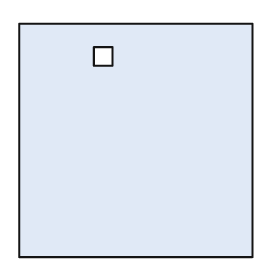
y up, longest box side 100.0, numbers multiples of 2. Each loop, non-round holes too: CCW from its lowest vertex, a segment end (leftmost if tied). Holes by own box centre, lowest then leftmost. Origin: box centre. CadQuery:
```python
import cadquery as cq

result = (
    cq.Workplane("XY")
    .moveTo(-50.0, -50.0)
    .lineTo(50.0, -50.0)
    .lineTo(50.0, 50.0)
    .lineTo(-50.0, 50.0)
    .close()
    .moveTo(-18.0, 32.0)
    .lineTo(-10.0, 32.0)
    .lineTo(-10.0, 40.0)
    .lineTo(-18.0, 40.0)
    .close()
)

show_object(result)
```